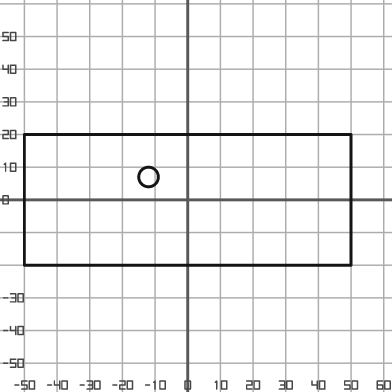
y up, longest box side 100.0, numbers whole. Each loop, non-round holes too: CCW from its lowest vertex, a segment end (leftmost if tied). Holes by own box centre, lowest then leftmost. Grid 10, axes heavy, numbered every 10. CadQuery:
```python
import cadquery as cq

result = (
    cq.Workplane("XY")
    .moveTo(-50.0, -20.0)
    .lineTo(50.0, -20.0)
    .lineTo(50.0, 20.0)
    .lineTo(-50.0, 20.0)
    .close()
    .moveTo(-12.0, 7.0)
    .circle(3.0)
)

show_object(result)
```